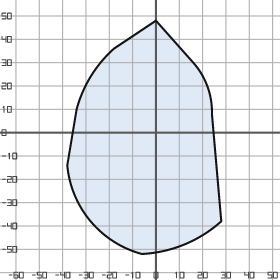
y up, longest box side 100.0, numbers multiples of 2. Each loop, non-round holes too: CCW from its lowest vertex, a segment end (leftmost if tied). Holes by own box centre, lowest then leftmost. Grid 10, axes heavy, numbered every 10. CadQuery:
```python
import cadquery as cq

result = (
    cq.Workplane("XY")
    .moveTo(-6.0, -52.0)
    .threePointArc((12.0, -48.0), (28.0, -38.0))
    .lineTo(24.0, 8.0)
    .threePointArc((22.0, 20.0), (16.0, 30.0))
    .lineTo(0.0, 48.0)
    .lineTo(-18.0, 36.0)
    .threePointArc((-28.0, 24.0), (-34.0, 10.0))
    .lineTo(-38.0, -14.0)
    .threePointArc((-28.0, -38.0), (-6.0, -52.0))
    .close()
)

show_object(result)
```